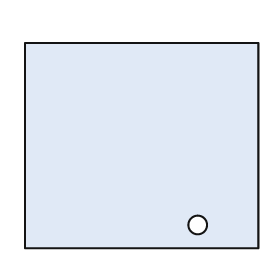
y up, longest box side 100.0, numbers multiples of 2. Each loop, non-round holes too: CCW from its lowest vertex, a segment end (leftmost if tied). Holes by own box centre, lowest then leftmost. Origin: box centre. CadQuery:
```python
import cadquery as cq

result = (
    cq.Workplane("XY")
    .moveTo(-50.0, -44.0)
    .lineTo(50.0, -44.0)
    .lineTo(50.0, 44.0)
    .lineTo(-50.0, 44.0)
    .close()
    .moveTo(24.0, -34.0)
    .circle(4.0)
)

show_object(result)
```